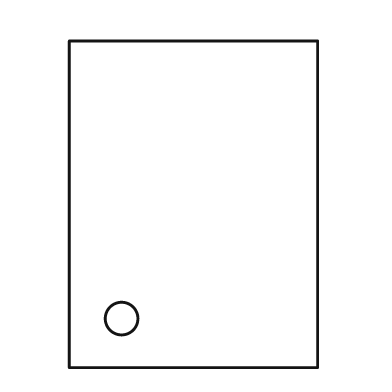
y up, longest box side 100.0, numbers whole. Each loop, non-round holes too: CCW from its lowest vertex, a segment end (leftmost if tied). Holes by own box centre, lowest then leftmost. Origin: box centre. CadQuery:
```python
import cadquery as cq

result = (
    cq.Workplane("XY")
    .moveTo(-38.0, -50.0)
    .lineTo(38.0, -50.0)
    .lineTo(38.0, 50.0)
    .lineTo(-38.0, 50.0)
    .close()
    .moveTo(-22.0, -35.0)
    .circle(5.0)
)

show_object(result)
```